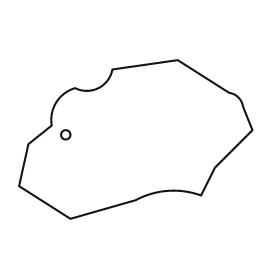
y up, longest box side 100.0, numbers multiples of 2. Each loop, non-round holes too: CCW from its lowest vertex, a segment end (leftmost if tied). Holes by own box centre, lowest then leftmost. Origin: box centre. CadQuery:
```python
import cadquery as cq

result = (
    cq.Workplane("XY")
    .moveTo(-28.0, -34.0)
    .lineTo(0.0, -26.0)
    .threePointArc((14.0, -22.0), (28.0, -24.0))
    .lineTo(34.0, -12.0)
    .lineTo(50.0, 4.0)
    .lineTo(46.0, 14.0)
    .threePointArc((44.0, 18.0), (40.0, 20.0))
    .lineTo(18.0, 34.0)
    .lineTo(-10.0, 30.0)
    .threePointArc((-16.0, 22.0), (-26.0, 22.0))
    .threePointArc((-34.0, 16.0), (-36.0, 6.0))
    .lineTo(-46.0, -2.0)
    .lineTo(-50.0, -20.0)
    .close()
    .moveTo(-30.0, 2.0)
    .circle(2.0)
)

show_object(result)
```